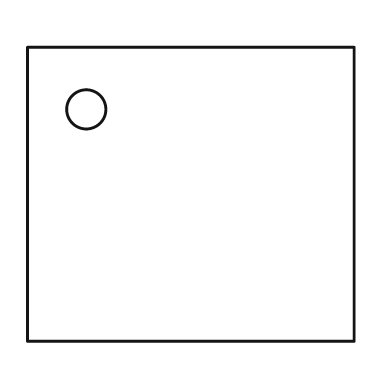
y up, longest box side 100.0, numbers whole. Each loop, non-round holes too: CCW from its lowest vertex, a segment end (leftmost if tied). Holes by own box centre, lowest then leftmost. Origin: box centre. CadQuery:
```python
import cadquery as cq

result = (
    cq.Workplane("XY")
    .moveTo(-50.0, -45.0)
    .lineTo(50.0, -45.0)
    .lineTo(50.0, 45.0)
    .lineTo(-50.0, 45.0)
    .close()
    .moveTo(-32.0, 26.0)
    .circle(6.0)
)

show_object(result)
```